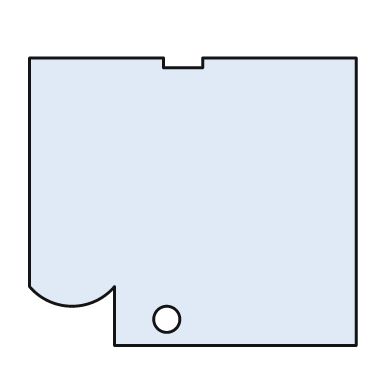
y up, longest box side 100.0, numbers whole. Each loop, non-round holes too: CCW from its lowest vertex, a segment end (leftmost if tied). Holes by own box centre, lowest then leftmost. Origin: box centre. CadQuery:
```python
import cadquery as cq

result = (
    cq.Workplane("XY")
    .moveTo(-24.0, -44.0)
    .lineTo(50.0, -44.0)
    .lineTo(50.0, 44.0)
    .lineTo(3.0, 44.0)
    .lineTo(3.0, 41.0)
    .lineTo(-9.0, 41.0)
    .lineTo(-9.0, 44.0)
    .lineTo(-50.0, 44.0)
    .lineTo(-50.0, -26.0)
    .threePointArc((-37.0, -32.0), (-24.0, -26.0))
    .close()
    .moveTo(-8.0, -36.0)
    .circle(4.0)
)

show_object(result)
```